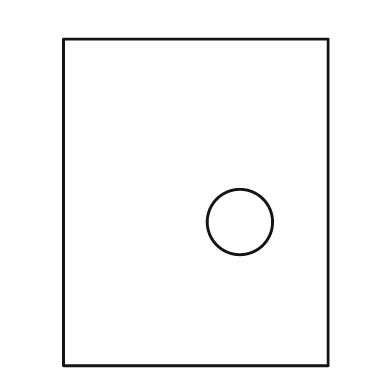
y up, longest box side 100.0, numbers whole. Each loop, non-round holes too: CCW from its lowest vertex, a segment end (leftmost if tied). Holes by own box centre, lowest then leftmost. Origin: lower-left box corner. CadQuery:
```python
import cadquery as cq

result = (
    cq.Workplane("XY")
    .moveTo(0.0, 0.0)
    .lineTo(81.0, 0.0)
    .lineTo(81.0, 100.0)
    .lineTo(0.0, 100.0)
    .close()
    .moveTo(54.0, 44.0)
    .circle(10.0)
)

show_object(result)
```